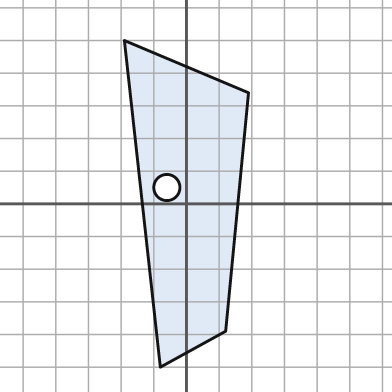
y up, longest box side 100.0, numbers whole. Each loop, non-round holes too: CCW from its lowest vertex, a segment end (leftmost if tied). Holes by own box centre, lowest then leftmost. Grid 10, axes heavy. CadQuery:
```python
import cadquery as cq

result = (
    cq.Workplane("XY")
    .moveTo(-8.0, -50.0)
    .lineTo(12.0, -39.0)
    .lineTo(19.0, 34.0)
    .lineTo(-19.0, 50.0)
    .close()
    .moveTo(-6.0, 5.0)
    .circle(4.0)
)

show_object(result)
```